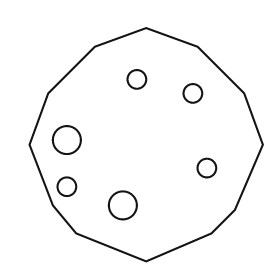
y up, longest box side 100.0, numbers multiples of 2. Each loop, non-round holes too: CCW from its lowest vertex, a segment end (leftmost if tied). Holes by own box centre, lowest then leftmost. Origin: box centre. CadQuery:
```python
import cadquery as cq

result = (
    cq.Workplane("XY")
    .moveTo(0.0, -50.0)
    .lineTo(28.0, -38.0)
    .lineTo(38.0, -28.0)
    .lineTo(50.0, 0.0)
    .lineTo(42.0, 22.0)
    .lineTo(22.0, 42.0)
    .lineTo(0.0, 50.0)
    .lineTo(-22.0, 42.0)
    .lineTo(-42.0, 22.0)
    .lineTo(-50.0, 0.0)
    .lineTo(-40.0, -26.0)
    .lineTo(-30.0, -38.0)
    .close()
    .moveTo(-10.0, -26.0)
    .circle(6.0)
    .moveTo(-34.0, -18.0)
    .circle(4.0)
    .moveTo(26.0, -10.0)
    .circle(4.0)
    .moveTo(-34.0, 2.0)
    .circle(6.0)
    .moveTo(20.0, 22.0)
    .circle(4.0)
    .moveTo(-4.0, 28.0)
    .circle(4.0)
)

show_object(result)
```